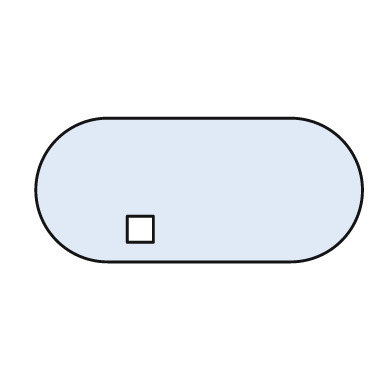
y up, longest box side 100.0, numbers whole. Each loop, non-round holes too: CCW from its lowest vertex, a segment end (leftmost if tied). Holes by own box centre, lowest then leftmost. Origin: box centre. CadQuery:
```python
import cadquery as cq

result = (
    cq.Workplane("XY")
    .moveTo(-28.0, -22.0)
    .lineTo(28.0, -22.0)
    .threePointArc((50.0, 0.0), (28.0, 22.0))
    .lineTo(-28.0, 22.0)
    .threePointArc((-50.0, 0.0), (-28.0, -22.0))
    .close()
    .moveTo(-22.0, -16.0)
    .lineTo(-14.0, -16.0)
    .lineTo(-14.0, -8.0)
    .lineTo(-22.0, -8.0)
    .close()
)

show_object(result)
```